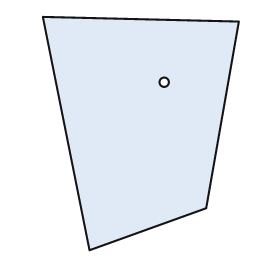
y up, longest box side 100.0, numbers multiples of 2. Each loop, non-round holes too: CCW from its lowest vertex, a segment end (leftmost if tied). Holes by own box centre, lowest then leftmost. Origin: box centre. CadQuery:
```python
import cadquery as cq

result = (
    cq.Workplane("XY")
    .moveTo(-22.0, -50.0)
    .lineTo(28.0, -32.0)
    .lineTo(42.0, 48.0)
    .lineTo(-42.0, 50.0)
    .close()
    .moveTo(10.0, 22.0)
    .circle(2.0)
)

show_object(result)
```